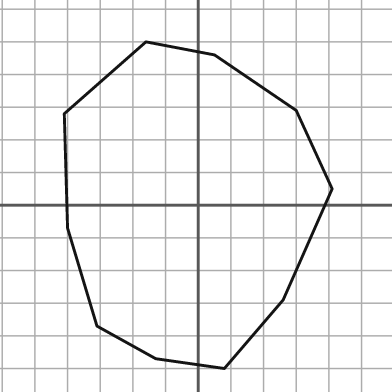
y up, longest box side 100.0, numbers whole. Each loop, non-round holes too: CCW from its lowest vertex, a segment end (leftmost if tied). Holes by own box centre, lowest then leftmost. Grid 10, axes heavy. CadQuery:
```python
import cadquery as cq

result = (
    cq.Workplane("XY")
    .moveTo(8.0, -50.0)
    .lineTo(26.0, -29.0)
    .lineTo(41.0, 5.0)
    .lineTo(30.0, 29.0)
    .lineTo(5.0, 46.0)
    .lineTo(-16.0, 50.0)
    .lineTo(-41.0, 28.0)
    .lineTo(-40.0, -7.0)
    .lineTo(-31.0, -37.0)
    .lineTo(-13.0, -47.0)
    .close()
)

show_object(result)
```